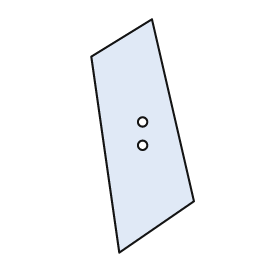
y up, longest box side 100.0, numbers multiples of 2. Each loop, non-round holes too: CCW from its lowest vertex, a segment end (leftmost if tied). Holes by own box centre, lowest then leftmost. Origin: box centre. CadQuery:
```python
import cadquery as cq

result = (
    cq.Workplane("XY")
    .moveTo(-10.0, -50.0)
    .lineTo(22.0, -28.0)
    .lineTo(4.0, 50.0)
    .lineTo(-22.0, 34.0)
    .close()
    .moveTo(0.0, -4.0)
    .circle(2.0)
    .moveTo(0.0, 6.0)
    .circle(2.0)
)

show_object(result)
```